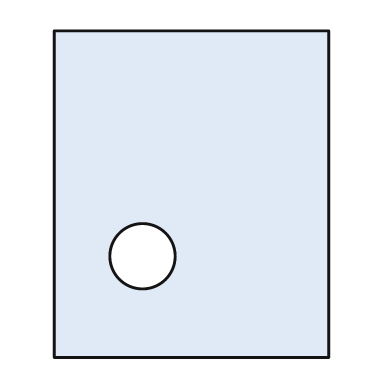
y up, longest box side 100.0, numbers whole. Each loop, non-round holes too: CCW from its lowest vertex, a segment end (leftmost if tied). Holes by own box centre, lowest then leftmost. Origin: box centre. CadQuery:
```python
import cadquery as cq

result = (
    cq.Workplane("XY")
    .moveTo(-42.0, -50.0)
    .lineTo(42.0, -50.0)
    .lineTo(42.0, 50.0)
    .lineTo(-42.0, 50.0)
    .close()
    .moveTo(-15.0, -19.0)
    .circle(10.0)
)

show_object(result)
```